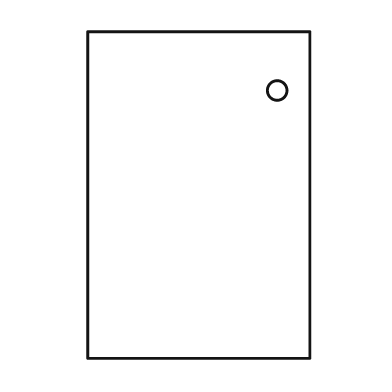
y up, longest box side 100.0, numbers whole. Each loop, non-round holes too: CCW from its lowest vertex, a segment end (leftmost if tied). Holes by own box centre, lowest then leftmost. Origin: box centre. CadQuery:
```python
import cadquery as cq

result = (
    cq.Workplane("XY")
    .moveTo(-34.0, -50.0)
    .lineTo(34.0, -50.0)
    .lineTo(34.0, 50.0)
    .lineTo(-34.0, 50.0)
    .close()
    .moveTo(24.0, 32.0)
    .circle(3.0)
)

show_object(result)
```